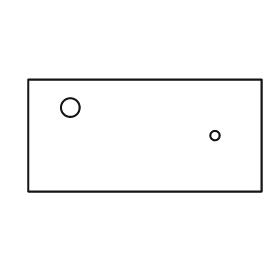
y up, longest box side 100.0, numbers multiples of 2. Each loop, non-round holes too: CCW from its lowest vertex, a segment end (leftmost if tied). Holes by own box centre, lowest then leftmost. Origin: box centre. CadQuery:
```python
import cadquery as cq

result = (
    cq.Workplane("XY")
    .moveTo(-50.0, -24.0)
    .lineTo(50.0, -24.0)
    .lineTo(50.0, 24.0)
    .lineTo(-50.0, 24.0)
    .close()
    .moveTo(30.0, 0.0)
    .circle(2.0)
    .moveTo(-32.0, 12.0)
    .circle(4.0)
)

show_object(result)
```